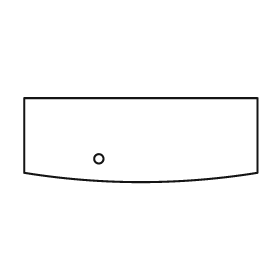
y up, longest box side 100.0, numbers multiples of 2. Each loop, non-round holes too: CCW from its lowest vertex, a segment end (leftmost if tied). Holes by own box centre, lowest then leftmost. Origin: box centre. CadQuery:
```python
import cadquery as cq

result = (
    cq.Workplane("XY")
    .moveTo(-50.0, -14.0)
    .threePointArc((0.0, -18.0), (50.0, -14.0))
    .lineTo(50.0, 18.0)
    .lineTo(-50.0, 18.0)
    .close()
    .moveTo(-18.0, -8.0)
    .circle(2.0)
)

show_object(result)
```